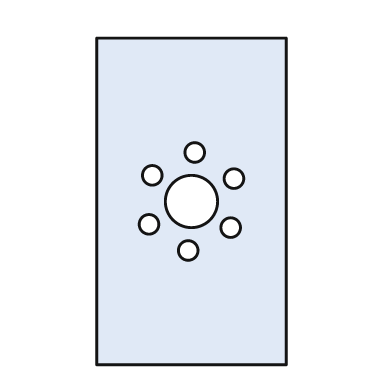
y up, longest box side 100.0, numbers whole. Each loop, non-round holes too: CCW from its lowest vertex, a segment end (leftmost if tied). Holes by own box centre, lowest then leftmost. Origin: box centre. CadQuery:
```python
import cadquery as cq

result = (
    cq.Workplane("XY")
    .moveTo(-29.0, -50.0)
    .lineTo(29.0, -50.0)
    .lineTo(29.0, 50.0)
    .lineTo(-29.0, 50.0)
    .close()
    .moveTo(-1.0, -15.0)
    .circle(3.0)
    .moveTo(12.0, -8.0)
    .circle(3.0)
    .moveTo(-13.0, -7.0)
    .circle(3.0)
    .moveTo(0.0, 0.0)
    .circle(8.0)
    .moveTo(13.0, 7.0)
    .circle(3.0)
    .moveTo(-12.0, 8.0)
    .circle(3.0)
    .moveTo(1.0, 15.0)
    .circle(3.0)
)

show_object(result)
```